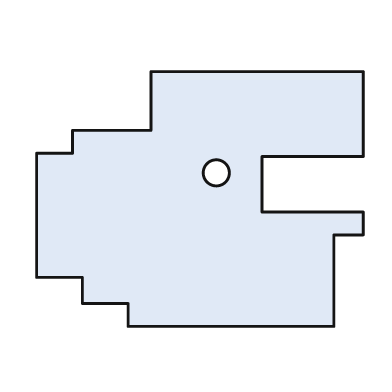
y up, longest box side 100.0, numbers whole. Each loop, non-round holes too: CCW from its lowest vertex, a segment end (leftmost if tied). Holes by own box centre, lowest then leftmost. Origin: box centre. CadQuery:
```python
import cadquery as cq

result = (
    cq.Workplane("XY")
    .moveTo(-22.0, -39.0)
    .lineTo(41.0, -39.0)
    .lineTo(41.0, -11.0)
    .lineTo(50.0, -11.0)
    .lineTo(50.0, -4.0)
    .lineTo(19.0, -4.0)
    .lineTo(19.0, 13.0)
    .lineTo(50.0, 13.0)
    .lineTo(50.0, 39.0)
    .lineTo(-15.0, 39.0)
    .lineTo(-15.0, 21.0)
    .lineTo(-39.0, 21.0)
    .lineTo(-39.0, 14.0)
    .lineTo(-50.0, 14.0)
    .lineTo(-50.0, -24.0)
    .lineTo(-36.0, -24.0)
    .lineTo(-36.0, -32.0)
    .lineTo(-22.0, -32.0)
    .close()
    .moveTo(5.0, 8.0)
    .circle(4.0)
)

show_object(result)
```